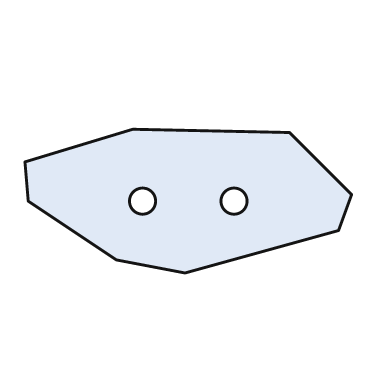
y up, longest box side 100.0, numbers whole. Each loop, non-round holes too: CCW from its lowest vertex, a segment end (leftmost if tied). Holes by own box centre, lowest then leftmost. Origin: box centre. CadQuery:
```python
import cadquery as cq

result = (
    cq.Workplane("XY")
    .moveTo(-1.0, -22.0)
    .lineTo(46.0, -9.0)
    .lineTo(50.0, 2.0)
    .lineTo(31.0, 21.0)
    .lineTo(-17.0, 22.0)
    .lineTo(-50.0, 12.0)
    .lineTo(-49.0, 0.0)
    .lineTo(-22.0, -18.0)
    .close()
    .moveTo(-14.0, 0.0)
    .circle(4.0)
    .moveTo(14.0, 0.0)
    .circle(4.0)
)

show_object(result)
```